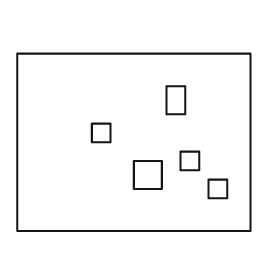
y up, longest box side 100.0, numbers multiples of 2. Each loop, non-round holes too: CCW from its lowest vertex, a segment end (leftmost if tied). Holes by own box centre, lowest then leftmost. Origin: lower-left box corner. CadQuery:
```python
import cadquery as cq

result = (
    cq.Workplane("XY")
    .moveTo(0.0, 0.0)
    .lineTo(100.0, 0.0)
    .lineTo(100.0, 76.0)
    .lineTo(0.0, 76.0)
    .close()
    .moveTo(82.0, 14.0)
    .lineTo(90.0, 14.0)
    .lineTo(90.0, 22.0)
    .lineTo(82.0, 22.0)
    .close()
    .moveTo(50.0, 18.0)
    .lineTo(62.0, 18.0)
    .lineTo(62.0, 30.0)
    .lineTo(50.0, 30.0)
    .close()
    .moveTo(70.0, 26.0)
    .lineTo(78.0, 26.0)
    .lineTo(78.0, 34.0)
    .lineTo(70.0, 34.0)
    .close()
    .moveTo(32.0, 38.0)
    .lineTo(40.0, 38.0)
    .lineTo(40.0, 46.0)
    .lineTo(32.0, 46.0)
    .close()
    .moveTo(64.0, 50.0)
    .lineTo(72.0, 50.0)
    .lineTo(72.0, 62.0)
    .lineTo(64.0, 62.0)
    .close()
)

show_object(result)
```